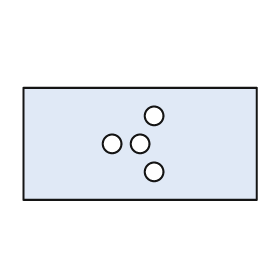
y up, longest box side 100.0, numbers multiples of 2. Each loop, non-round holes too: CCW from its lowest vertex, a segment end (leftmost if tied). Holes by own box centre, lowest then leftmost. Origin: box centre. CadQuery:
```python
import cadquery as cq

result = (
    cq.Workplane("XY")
    .moveTo(-50.0, -24.0)
    .lineTo(50.0, -24.0)
    .lineTo(50.0, 24.0)
    .lineTo(-50.0, 24.0)
    .close()
    .moveTo(6.0, -12.0)
    .circle(4.0)
    .moveTo(-12.0, 0.0)
    .circle(4.0)
    .moveTo(0.0, 0.0)
    .circle(4.0)
    .moveTo(6.0, 12.0)
    .circle(4.0)
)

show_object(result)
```